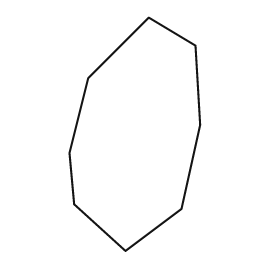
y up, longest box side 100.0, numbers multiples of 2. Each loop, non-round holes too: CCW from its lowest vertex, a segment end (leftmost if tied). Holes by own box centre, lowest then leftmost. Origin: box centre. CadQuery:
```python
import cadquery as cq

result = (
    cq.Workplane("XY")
    .moveTo(-4.0, -50.0)
    .lineTo(20.0, -32.0)
    .lineTo(28.0, 4.0)
    .lineTo(26.0, 38.0)
    .lineTo(6.0, 50.0)
    .lineTo(-20.0, 24.0)
    .lineTo(-28.0, -8.0)
    .lineTo(-26.0, -30.0)
    .close()
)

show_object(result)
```